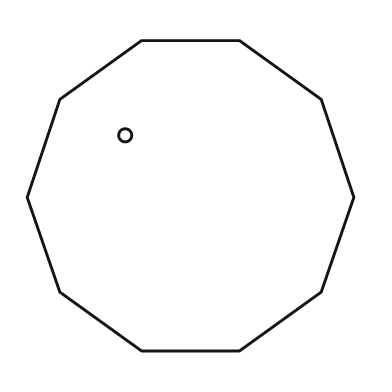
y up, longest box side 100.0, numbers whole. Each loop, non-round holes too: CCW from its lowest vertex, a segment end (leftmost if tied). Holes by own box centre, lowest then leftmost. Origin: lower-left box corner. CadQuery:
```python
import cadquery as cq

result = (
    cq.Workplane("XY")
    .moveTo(35.0, 0.0)
    .lineTo(65.0, 0.0)
    .lineTo(90.0, 18.0)
    .lineTo(100.0, 47.0)
    .lineTo(90.0, 77.0)
    .lineTo(65.0, 95.0)
    .lineTo(35.0, 95.0)
    .lineTo(10.0, 77.0)
    .lineTo(0.0, 47.0)
    .lineTo(10.0, 18.0)
    .close()
    .moveTo(30.0, 66.0)
    .circle(2.0)
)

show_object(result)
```